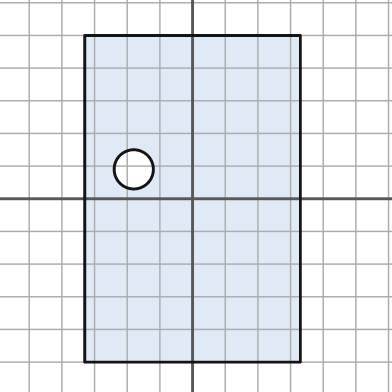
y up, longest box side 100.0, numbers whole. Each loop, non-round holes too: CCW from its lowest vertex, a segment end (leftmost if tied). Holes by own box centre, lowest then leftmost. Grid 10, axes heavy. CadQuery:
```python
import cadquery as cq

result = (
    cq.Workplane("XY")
    .moveTo(-33.0, -50.0)
    .lineTo(33.0, -50.0)
    .lineTo(33.0, 50.0)
    .lineTo(-33.0, 50.0)
    .close()
    .moveTo(-18.0, 9.0)
    .circle(6.0)
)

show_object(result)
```